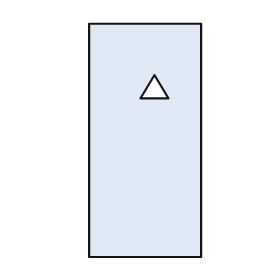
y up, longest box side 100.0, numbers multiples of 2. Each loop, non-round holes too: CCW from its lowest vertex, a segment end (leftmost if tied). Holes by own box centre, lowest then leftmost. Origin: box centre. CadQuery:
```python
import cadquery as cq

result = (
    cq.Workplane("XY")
    .moveTo(-24.0, -50.0)
    .lineTo(24.0, -50.0)
    .lineTo(24.0, 50.0)
    .lineTo(-24.0, 50.0)
    .close()
    .moveTo(-2.0, 18.0)
    .lineTo(10.0, 18.0)
    .lineTo(4.0, 28.0)
    .close()
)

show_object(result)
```